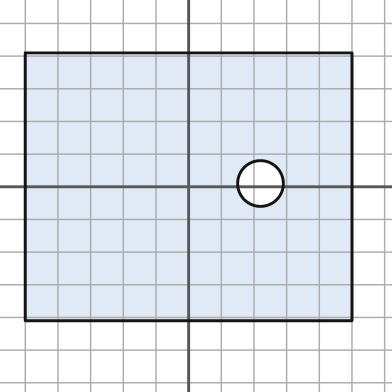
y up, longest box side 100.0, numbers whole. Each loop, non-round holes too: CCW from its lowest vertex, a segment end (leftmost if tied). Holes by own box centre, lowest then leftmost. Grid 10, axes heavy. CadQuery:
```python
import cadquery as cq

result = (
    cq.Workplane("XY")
    .moveTo(-50.0, -41.0)
    .lineTo(50.0, -41.0)
    .lineTo(50.0, 41.0)
    .lineTo(-50.0, 41.0)
    .close()
    .moveTo(22.0, 1.0)
    .circle(7.0)
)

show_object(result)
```